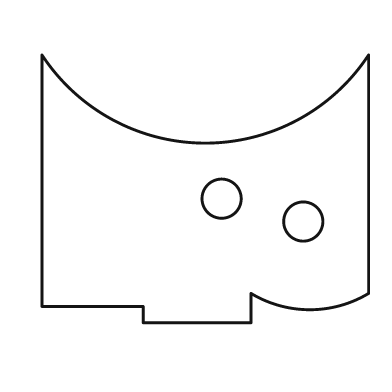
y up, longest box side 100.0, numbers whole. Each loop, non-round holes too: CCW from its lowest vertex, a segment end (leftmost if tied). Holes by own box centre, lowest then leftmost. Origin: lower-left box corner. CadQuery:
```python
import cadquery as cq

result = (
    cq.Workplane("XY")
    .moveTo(31.0, 0.0)
    .lineTo(64.0, 0.0)
    .lineTo(64.0, 9.0)
    .threePointArc((82.0, 4.0), (100.0, 9.0))
    .lineTo(100.0, 82.0)
    .threePointArc((50.0, 55.0), (0.0, 82.0))
    .lineTo(0.0, 5.0)
    .lineTo(31.0, 5.0)
    .close()
    .moveTo(80.0, 31.0)
    .circle(6.0)
    .moveTo(55.0, 38.0)
    .circle(6.0)
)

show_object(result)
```